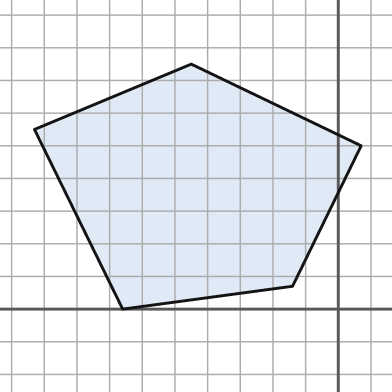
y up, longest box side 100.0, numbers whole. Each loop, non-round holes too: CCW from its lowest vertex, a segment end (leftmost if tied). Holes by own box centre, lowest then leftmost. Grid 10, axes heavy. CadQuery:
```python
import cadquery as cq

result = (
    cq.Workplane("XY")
    .moveTo(-66.0, 0.0)
    .lineTo(-14.0, 7.0)
    .lineTo(7.0, 50.0)
    .lineTo(-45.0, 75.0)
    .lineTo(-93.0, 55.0)
    .close()
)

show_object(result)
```